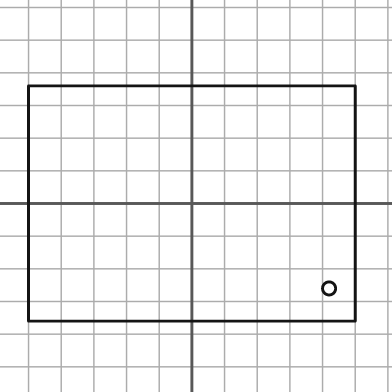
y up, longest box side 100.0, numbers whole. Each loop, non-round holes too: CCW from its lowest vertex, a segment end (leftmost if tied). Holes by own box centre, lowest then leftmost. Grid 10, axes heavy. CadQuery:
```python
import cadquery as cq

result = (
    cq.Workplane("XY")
    .moveTo(-50.0, -36.0)
    .lineTo(50.0, -36.0)
    .lineTo(50.0, 36.0)
    .lineTo(-50.0, 36.0)
    .close()
    .moveTo(42.0, -26.0)
    .circle(2.0)
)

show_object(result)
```